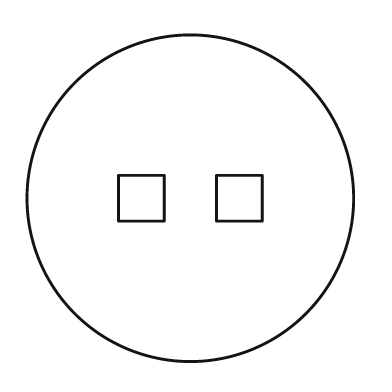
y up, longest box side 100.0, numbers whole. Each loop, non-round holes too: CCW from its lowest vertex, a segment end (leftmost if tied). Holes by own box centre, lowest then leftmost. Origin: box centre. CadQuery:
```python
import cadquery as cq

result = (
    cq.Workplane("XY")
    .moveTo(0.0, 0.0)
    .circle(50.0)
    .moveTo(-22.0, -7.0)
    .lineTo(-8.0, -7.0)
    .lineTo(-8.0, 7.0)
    .lineTo(-22.0, 7.0)
    .close()
    .moveTo(8.0, -7.0)
    .lineTo(22.0, -7.0)
    .lineTo(22.0, 7.0)
    .lineTo(8.0, 7.0)
    .close()
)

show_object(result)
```